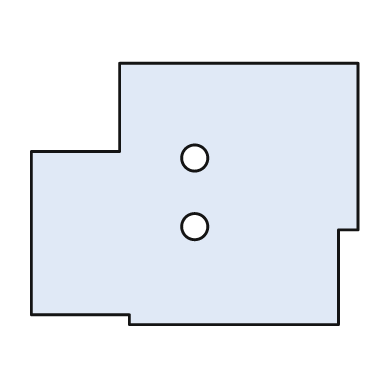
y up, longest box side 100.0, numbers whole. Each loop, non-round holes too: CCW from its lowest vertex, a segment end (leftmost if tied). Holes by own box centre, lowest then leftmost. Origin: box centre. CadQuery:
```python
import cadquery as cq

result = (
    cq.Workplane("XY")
    .moveTo(-20.0, -40.0)
    .lineTo(44.0, -40.0)
    .lineTo(44.0, -11.0)
    .lineTo(50.0, -11.0)
    .lineTo(50.0, 40.0)
    .lineTo(-23.0, 40.0)
    .lineTo(-23.0, 13.0)
    .lineTo(-50.0, 13.0)
    .lineTo(-50.0, -37.0)
    .lineTo(-20.0, -37.0)
    .close()
    .moveTo(0.0, -10.0)
    .circle(4.0)
    .moveTo(0.0, 11.0)
    .circle(4.0)
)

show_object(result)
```